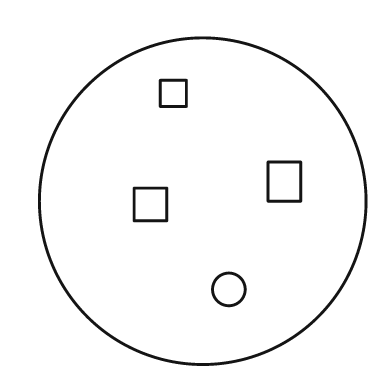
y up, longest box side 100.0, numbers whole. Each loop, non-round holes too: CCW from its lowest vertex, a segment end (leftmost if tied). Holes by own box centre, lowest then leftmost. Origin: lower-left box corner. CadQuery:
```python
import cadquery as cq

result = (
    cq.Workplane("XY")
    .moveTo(50.0, 50.0)
    .circle(50.0)
    .moveTo(58.0, 23.0)
    .circle(5.0)
    .moveTo(29.0, 44.0)
    .lineTo(39.0, 44.0)
    .lineTo(39.0, 54.0)
    .lineTo(29.0, 54.0)
    .close()
    .moveTo(70.0, 50.0)
    .lineTo(80.0, 50.0)
    .lineTo(80.0, 62.0)
    .lineTo(70.0, 62.0)
    .close()
    .moveTo(37.0, 79.0)
    .lineTo(45.0, 79.0)
    .lineTo(45.0, 87.0)
    .lineTo(37.0, 87.0)
    .close()
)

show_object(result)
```